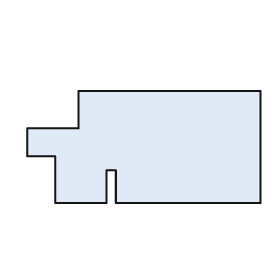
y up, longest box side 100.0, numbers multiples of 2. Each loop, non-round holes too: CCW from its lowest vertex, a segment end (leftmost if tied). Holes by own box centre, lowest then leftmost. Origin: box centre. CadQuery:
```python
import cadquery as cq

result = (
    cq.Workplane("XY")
    .moveTo(-38.0, -24.0)
    .lineTo(-16.0, -24.0)
    .lineTo(-16.0, -10.0)
    .lineTo(-12.0, -10.0)
    .lineTo(-12.0, -24.0)
    .lineTo(50.0, -24.0)
    .lineTo(50.0, 24.0)
    .lineTo(-28.0, 24.0)
    .lineTo(-28.0, 8.0)
    .lineTo(-50.0, 8.0)
    .lineTo(-50.0, -4.0)
    .lineTo(-38.0, -4.0)
    .close()
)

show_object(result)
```